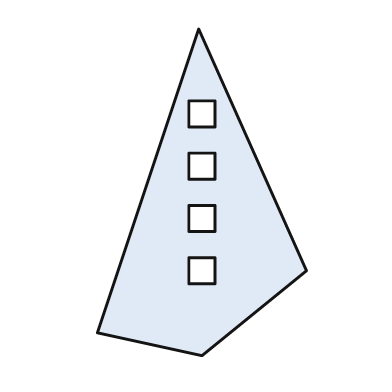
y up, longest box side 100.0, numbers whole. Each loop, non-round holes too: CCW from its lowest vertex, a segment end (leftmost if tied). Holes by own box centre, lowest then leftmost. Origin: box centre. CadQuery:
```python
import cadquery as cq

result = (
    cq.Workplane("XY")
    .moveTo(0.0, -50.0)
    .lineTo(32.0, -24.0)
    .lineTo(-1.0, 50.0)
    .lineTo(-32.0, -43.0)
    .close()
    .moveTo(-4.0, -28.0)
    .lineTo(4.0, -28.0)
    .lineTo(4.0, -20.0)
    .lineTo(-4.0, -20.0)
    .close()
    .moveTo(-4.0, -12.0)
    .lineTo(4.0, -12.0)
    .lineTo(4.0, -4.0)
    .lineTo(-4.0, -4.0)
    .close()
    .moveTo(-4.0, 4.0)
    .lineTo(4.0, 4.0)
    .lineTo(4.0, 12.0)
    .lineTo(-4.0, 12.0)
    .close()
    .moveTo(-4.0, 20.0)
    .lineTo(4.0, 20.0)
    .lineTo(4.0, 28.0)
    .lineTo(-4.0, 28.0)
    .close()
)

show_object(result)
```